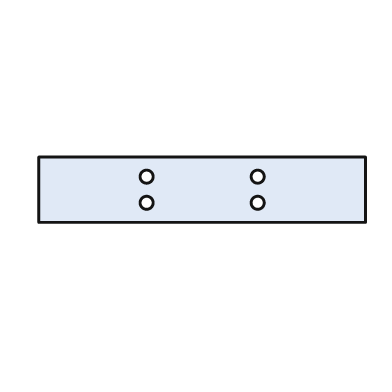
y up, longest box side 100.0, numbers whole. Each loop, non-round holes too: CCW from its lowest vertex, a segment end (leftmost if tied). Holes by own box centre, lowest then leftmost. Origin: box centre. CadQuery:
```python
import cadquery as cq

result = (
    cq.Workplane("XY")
    .moveTo(-50.0, -10.0)
    .lineTo(50.0, -10.0)
    .lineTo(50.0, 10.0)
    .lineTo(-50.0, 10.0)
    .close()
    .moveTo(-17.0, -4.0)
    .circle(2.0)
    .moveTo(17.0, -4.0)
    .circle(2.0)
    .moveTo(-17.0, 4.0)
    .circle(2.0)
    .moveTo(17.0, 4.0)
    .circle(2.0)
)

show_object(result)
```